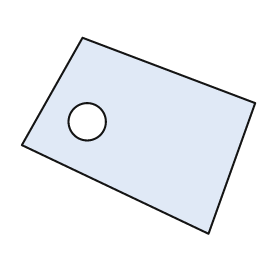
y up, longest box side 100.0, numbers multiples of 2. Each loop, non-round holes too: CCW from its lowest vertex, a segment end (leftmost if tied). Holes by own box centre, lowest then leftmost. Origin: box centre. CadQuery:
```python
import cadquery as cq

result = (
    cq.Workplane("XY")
    .moveTo(30.0, -42.0)
    .lineTo(50.0, 14.0)
    .lineTo(-24.0, 42.0)
    .lineTo(-50.0, -4.0)
    .close()
    .moveTo(-22.0, 6.0)
    .circle(8.0)
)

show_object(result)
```